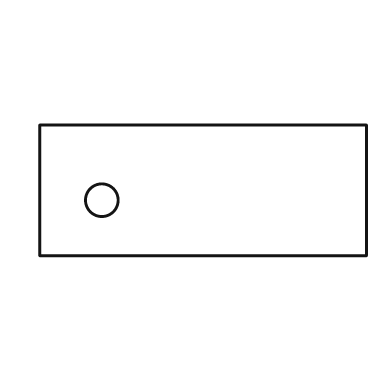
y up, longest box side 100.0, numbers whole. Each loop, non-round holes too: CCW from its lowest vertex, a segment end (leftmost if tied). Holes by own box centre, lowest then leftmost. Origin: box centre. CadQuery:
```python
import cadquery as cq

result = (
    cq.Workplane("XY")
    .moveTo(-50.0, -20.0)
    .lineTo(50.0, -20.0)
    .lineTo(50.0, 20.0)
    .lineTo(-50.0, 20.0)
    .close()
    .moveTo(-31.0, -3.0)
    .circle(5.0)
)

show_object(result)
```